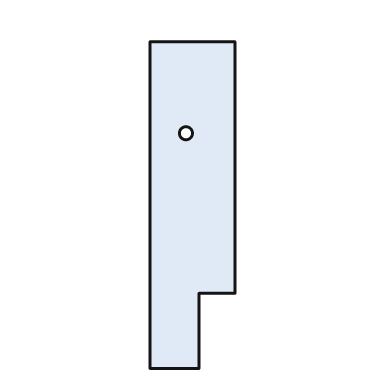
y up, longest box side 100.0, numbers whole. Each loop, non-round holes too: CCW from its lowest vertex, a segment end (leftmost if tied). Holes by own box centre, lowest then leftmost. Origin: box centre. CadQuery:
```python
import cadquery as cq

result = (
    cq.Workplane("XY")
    .moveTo(-13.0, -50.0)
    .lineTo(2.0, -50.0)
    .lineTo(2.0, -27.0)
    .lineTo(13.0, -27.0)
    .lineTo(13.0, 50.0)
    .lineTo(-13.0, 50.0)
    .close()
    .moveTo(-2.0, 22.0)
    .circle(2.0)
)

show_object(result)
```